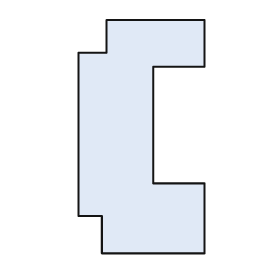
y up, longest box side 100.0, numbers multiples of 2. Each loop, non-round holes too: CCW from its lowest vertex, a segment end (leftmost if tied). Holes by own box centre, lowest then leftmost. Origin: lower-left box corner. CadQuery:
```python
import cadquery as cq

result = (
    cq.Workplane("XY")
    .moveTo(10.0, 0.0)
    .lineTo(54.0, 0.0)
    .lineTo(54.0, 30.0)
    .lineTo(32.0, 30.0)
    .lineTo(32.0, 80.0)
    .lineTo(54.0, 80.0)
    .lineTo(54.0, 100.0)
    .lineTo(12.0, 100.0)
    .lineTo(12.0, 86.0)
    .lineTo(0.0, 86.0)
    .lineTo(0.0, 16.0)
    .lineTo(10.0, 16.0)
    .close()
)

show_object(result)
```